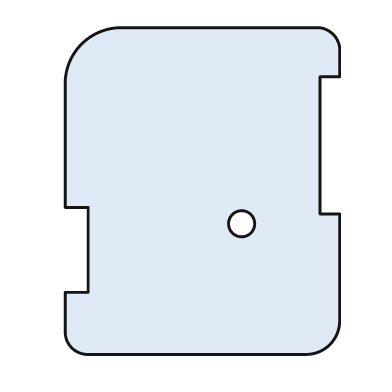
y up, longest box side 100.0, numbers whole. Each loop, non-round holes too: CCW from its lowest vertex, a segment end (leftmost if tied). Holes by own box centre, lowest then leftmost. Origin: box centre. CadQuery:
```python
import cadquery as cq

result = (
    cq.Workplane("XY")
    .moveTo(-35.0, -50.0)
    .lineTo(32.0, -50.0)
    .threePointArc((39.0, -47.0), (42.0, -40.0))
    .lineTo(42.0, -7.0)
    .lineTo(36.0, -7.0)
    .lineTo(36.0, 35.0)
    .lineTo(42.0, 35.0)
    .lineTo(42.0, 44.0)
    .threePointArc((40.0, 48.0), (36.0, 50.0))
    .lineTo(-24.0, 50.0)
    .threePointArc((-37.0, 45.0), (-42.0, 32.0))
    .lineTo(-42.0, -5.0)
    .lineTo(-35.0, -5.0)
    .lineTo(-35.0, -31.0)
    .lineTo(-42.0, -31.0)
    .lineTo(-42.0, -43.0)
    .threePointArc((-40.0, -48.0), (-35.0, -50.0))
    .close()
    .moveTo(12.0, -10.0)
    .circle(4.0)
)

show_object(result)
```